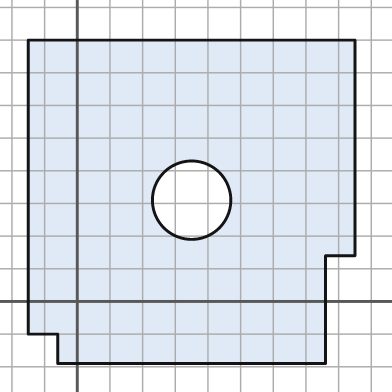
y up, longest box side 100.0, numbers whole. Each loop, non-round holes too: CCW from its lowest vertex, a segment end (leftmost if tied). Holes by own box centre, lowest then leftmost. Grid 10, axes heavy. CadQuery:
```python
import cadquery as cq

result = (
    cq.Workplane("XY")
    .moveTo(-6.0, -19.0)
    .lineTo(76.0, -19.0)
    .lineTo(76.0, 14.0)
    .lineTo(85.0, 14.0)
    .lineTo(85.0, 80.0)
    .lineTo(-15.0, 80.0)
    .lineTo(-15.0, -10.0)
    .lineTo(-6.0, -10.0)
    .close()
    .moveTo(35.0, 31.0)
    .circle(12.0)
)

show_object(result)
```